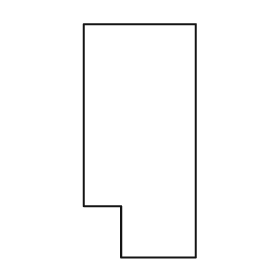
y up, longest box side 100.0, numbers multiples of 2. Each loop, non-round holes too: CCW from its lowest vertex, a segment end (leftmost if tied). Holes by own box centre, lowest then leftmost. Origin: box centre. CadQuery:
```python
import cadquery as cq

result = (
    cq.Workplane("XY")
    .moveTo(-8.0, -50.0)
    .lineTo(24.0, -50.0)
    .lineTo(24.0, 50.0)
    .lineTo(-24.0, 50.0)
    .lineTo(-24.0, -28.0)
    .lineTo(-8.0, -28.0)
    .close()
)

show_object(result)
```